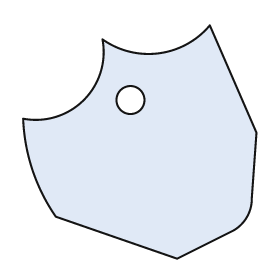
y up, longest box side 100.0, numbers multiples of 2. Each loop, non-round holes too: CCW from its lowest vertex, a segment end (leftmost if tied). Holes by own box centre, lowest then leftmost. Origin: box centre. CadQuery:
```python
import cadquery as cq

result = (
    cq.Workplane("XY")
    .moveTo(16.0, -50.0)
    .lineTo(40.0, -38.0)
    .threePointArc((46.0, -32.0), (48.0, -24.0))
    .lineTo(50.0, 4.0)
    .lineTo(30.0, 50.0)
    .threePointArc((8.0, 38.0), (-16.0, 44.0))
    .threePointArc((-24.0, 18.0), (-50.0, 10.0))
    .threePointArc((-46.0, -12.0), (-36.0, -32.0))
    .close()
    .moveTo(-4.0, 18.0)
    .circle(6.0)
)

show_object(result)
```